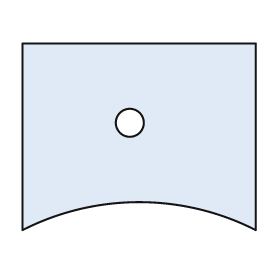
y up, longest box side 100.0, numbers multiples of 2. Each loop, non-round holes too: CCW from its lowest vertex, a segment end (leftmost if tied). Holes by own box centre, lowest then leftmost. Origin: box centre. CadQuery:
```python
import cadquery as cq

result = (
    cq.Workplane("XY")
    .moveTo(-50.0, -40.0)
    .threePointArc((0.0, -28.0), (50.0, -40.0))
    .lineTo(50.0, 40.0)
    .lineTo(-50.0, 40.0)
    .close()
    .moveTo(-4.0, 6.0)
    .circle(6.0)
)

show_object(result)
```